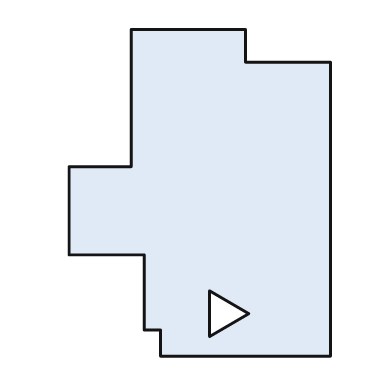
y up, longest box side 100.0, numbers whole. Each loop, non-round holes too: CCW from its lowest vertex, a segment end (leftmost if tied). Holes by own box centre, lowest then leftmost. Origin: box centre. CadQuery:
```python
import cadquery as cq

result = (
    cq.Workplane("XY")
    .moveTo(-12.0, -50.0)
    .lineTo(40.0, -50.0)
    .lineTo(40.0, 40.0)
    .lineTo(14.0, 40.0)
    .lineTo(14.0, 50.0)
    .lineTo(-21.0, 50.0)
    .lineTo(-21.0, 8.0)
    .lineTo(-40.0, 8.0)
    .lineTo(-40.0, -19.0)
    .lineTo(-17.0, -19.0)
    .lineTo(-17.0, -42.0)
    .lineTo(-12.0, -42.0)
    .close()
    .moveTo(3.0, -44.0)
    .lineTo(15.0, -37.0)
    .lineTo(3.0, -30.0)
    .close()
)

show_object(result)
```